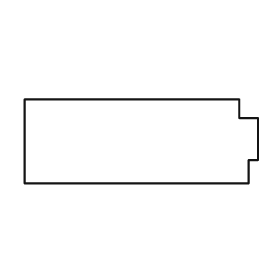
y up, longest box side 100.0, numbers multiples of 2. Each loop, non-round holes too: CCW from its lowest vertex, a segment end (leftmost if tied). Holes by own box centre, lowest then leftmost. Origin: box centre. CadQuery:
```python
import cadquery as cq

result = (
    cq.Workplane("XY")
    .moveTo(-50.0, -18.0)
    .lineTo(46.0, -18.0)
    .lineTo(46.0, -8.0)
    .lineTo(50.0, -8.0)
    .lineTo(50.0, 10.0)
    .lineTo(42.0, 10.0)
    .lineTo(42.0, 18.0)
    .lineTo(-50.0, 18.0)
    .close()
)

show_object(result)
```